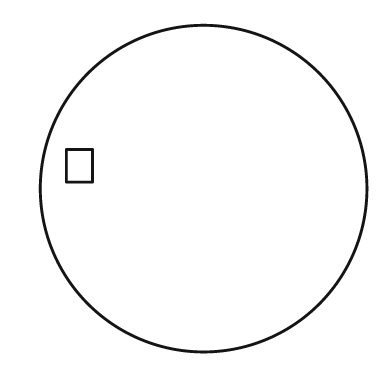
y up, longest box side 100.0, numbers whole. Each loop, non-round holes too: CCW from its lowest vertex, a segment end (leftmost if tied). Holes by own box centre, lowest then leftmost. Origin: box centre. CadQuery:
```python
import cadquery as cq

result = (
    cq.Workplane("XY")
    .moveTo(0.0, 0.0)
    .circle(50.0)
    .moveTo(-42.0, 2.0)
    .lineTo(-34.0, 2.0)
    .lineTo(-34.0, 12.0)
    .lineTo(-42.0, 12.0)
    .close()
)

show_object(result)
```